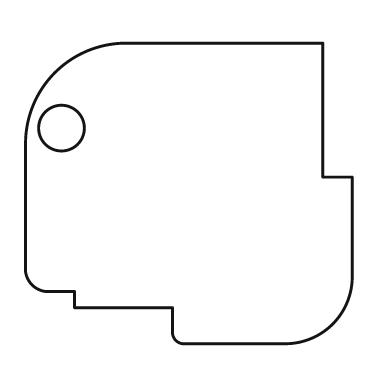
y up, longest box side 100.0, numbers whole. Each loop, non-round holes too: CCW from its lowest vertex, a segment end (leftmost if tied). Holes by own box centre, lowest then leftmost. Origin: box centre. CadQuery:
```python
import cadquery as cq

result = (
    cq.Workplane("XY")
    .moveTo(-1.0, -46.0)
    .lineTo(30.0, -46.0)
    .threePointArc((44.0, -40.0), (50.0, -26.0))
    .lineTo(50.0, 5.0)
    .lineTo(41.0, 5.0)
    .lineTo(41.0, 46.0)
    .lineTo(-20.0, 46.0)
    .threePointArc((-41.0, 37.0), (-50.0, 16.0))
    .lineTo(-50.0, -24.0)
    .threePointArc((-48.0, -28.0), (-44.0, -30.0))
    .lineTo(-35.0, -30.0)
    .lineTo(-35.0, -35.0)
    .lineTo(-5.0, -35.0)
    .lineTo(-5.0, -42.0)
    .threePointArc((-4.0, -45.0), (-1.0, -46.0))
    .close()
    .moveTo(-39.0, 20.0)
    .circle(7.0)
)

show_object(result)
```